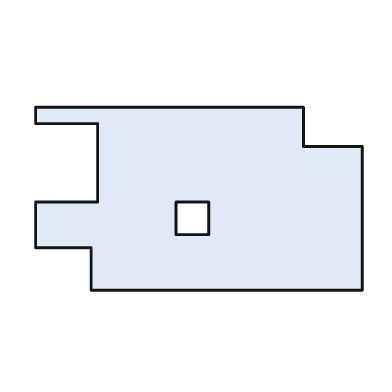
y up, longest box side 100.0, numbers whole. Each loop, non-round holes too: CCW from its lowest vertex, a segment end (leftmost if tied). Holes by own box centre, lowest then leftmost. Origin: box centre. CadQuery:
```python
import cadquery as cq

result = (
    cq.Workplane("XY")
    .moveTo(-33.0, -28.0)
    .lineTo(50.0, -28.0)
    .lineTo(50.0, 16.0)
    .lineTo(32.0, 16.0)
    .lineTo(32.0, 28.0)
    .lineTo(-50.0, 28.0)
    .lineTo(-50.0, 23.0)
    .lineTo(-31.0, 23.0)
    .lineTo(-31.0, -1.0)
    .lineTo(-50.0, -1.0)
    .lineTo(-50.0, -15.0)
    .lineTo(-33.0, -15.0)
    .close()
    .moveTo(-7.0, -11.0)
    .lineTo(3.0, -11.0)
    .lineTo(3.0, -1.0)
    .lineTo(-7.0, -1.0)
    .close()
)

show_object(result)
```